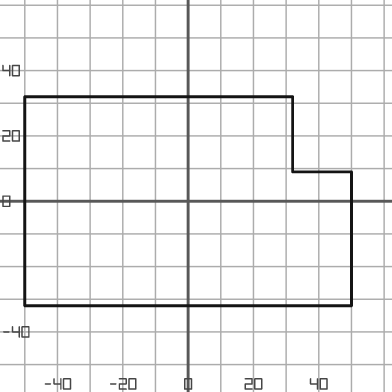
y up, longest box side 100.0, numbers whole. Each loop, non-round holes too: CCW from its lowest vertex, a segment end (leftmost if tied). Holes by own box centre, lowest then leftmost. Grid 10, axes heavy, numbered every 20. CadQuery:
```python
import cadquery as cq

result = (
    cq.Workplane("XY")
    .moveTo(-50.0, -32.0)
    .lineTo(50.0, -32.0)
    .lineTo(50.0, 9.0)
    .lineTo(32.0, 9.0)
    .lineTo(32.0, 32.0)
    .lineTo(-50.0, 32.0)
    .close()
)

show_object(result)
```